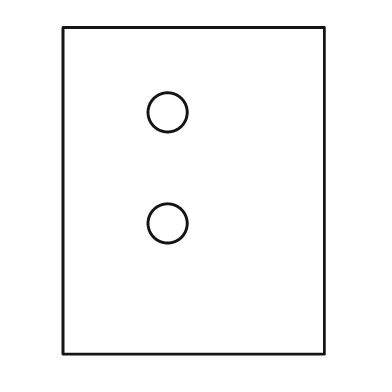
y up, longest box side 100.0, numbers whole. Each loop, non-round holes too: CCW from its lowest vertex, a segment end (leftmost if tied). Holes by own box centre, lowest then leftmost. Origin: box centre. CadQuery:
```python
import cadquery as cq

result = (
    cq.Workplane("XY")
    .moveTo(-40.0, -50.0)
    .lineTo(40.0, -50.0)
    .lineTo(40.0, 50.0)
    .lineTo(-40.0, 50.0)
    .close()
    .moveTo(-8.0, -10.0)
    .circle(6.0)
    .moveTo(-8.0, 24.0)
    .circle(6.0)
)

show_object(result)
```